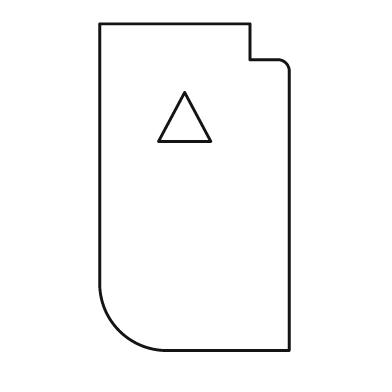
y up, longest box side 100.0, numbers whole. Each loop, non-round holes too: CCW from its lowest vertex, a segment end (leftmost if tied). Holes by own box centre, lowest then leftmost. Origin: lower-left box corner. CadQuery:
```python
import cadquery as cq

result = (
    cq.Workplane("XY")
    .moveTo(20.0, 0.0)
    .lineTo(58.0, 0.0)
    .lineTo(58.0, 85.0)
    .threePointArc((57.0, 88.0), (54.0, 89.0))
    .lineTo(46.0, 89.0)
    .lineTo(46.0, 100.0)
    .lineTo(0.0, 100.0)
    .lineTo(0.0, 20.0)
    .threePointArc((6.0, 6.0), (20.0, 0.0))
    .close()
    .moveTo(18.0, 64.0)
    .lineTo(34.0, 64.0)
    .lineTo(26.0, 79.0)
    .close()
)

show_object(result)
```